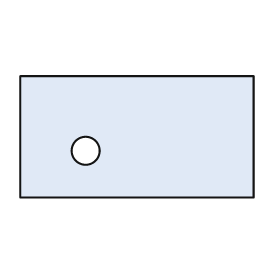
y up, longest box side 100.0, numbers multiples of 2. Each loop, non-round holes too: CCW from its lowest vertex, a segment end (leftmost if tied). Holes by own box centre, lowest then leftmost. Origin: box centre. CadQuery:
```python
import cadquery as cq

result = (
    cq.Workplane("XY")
    .moveTo(-50.0, -26.0)
    .lineTo(50.0, -26.0)
    .lineTo(50.0, 26.0)
    .lineTo(-50.0, 26.0)
    .close()
    .moveTo(-22.0, -6.0)
    .circle(6.0)
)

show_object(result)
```